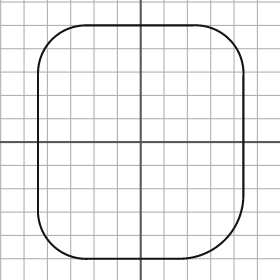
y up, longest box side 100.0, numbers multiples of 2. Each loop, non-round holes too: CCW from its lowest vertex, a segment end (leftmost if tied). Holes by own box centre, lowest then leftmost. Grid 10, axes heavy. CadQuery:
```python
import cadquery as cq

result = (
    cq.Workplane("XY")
    .moveTo(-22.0, -50.0)
    .lineTo(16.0, -50.0)
    .threePointArc((36.0, -42.0), (44.0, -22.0))
    .lineTo(44.0, 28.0)
    .threePointArc((38.0, 44.0), (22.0, 50.0))
    .lineTo(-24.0, 50.0)
    .threePointArc((-38.0, 44.0), (-44.0, 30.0))
    .lineTo(-44.0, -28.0)
    .threePointArc((-38.0, -44.0), (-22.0, -50.0))
    .close()
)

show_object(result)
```